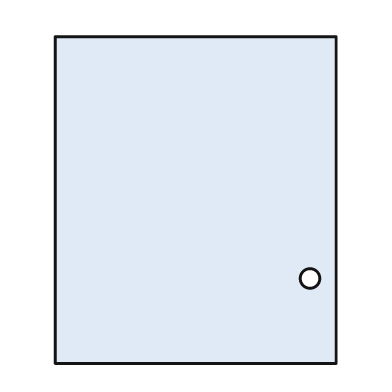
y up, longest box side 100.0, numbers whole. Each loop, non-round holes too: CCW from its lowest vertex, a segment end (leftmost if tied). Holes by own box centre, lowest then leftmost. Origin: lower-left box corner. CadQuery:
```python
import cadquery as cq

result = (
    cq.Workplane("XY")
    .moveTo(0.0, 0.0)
    .lineTo(86.0, 0.0)
    .lineTo(86.0, 100.0)
    .lineTo(0.0, 100.0)
    .close()
    .moveTo(78.0, 26.0)
    .circle(3.0)
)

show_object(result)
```